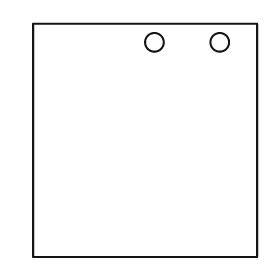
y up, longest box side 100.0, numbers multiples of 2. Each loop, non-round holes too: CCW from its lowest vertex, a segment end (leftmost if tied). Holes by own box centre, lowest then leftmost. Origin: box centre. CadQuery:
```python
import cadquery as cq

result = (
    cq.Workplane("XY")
    .moveTo(-48.0, -50.0)
    .lineTo(48.0, -50.0)
    .lineTo(48.0, 50.0)
    .lineTo(-48.0, 50.0)
    .close()
    .moveTo(4.0, 42.0)
    .circle(4.0)
    .moveTo(32.0, 42.0)
    .circle(4.0)
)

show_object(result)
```